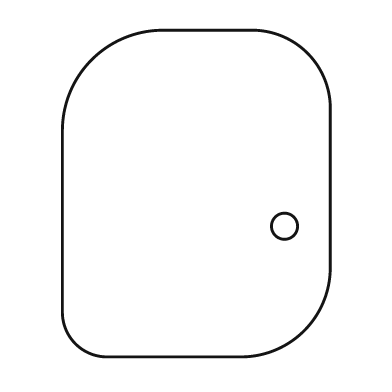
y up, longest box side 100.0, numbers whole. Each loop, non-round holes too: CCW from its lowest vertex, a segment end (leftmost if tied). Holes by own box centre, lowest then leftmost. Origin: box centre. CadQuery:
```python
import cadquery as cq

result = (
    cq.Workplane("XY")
    .moveTo(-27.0, -50.0)
    .lineTo(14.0, -50.0)
    .threePointArc((33.0, -42.0), (41.0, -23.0))
    .lineTo(41.0, 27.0)
    .threePointArc((34.0, 43.0), (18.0, 50.0))
    .lineTo(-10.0, 50.0)
    .threePointArc((-32.0, 41.0), (-41.0, 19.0))
    .lineTo(-41.0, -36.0)
    .threePointArc((-37.0, -46.0), (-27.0, -50.0))
    .close()
    .moveTo(27.0, -10.0)
    .circle(4.0)
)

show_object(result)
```